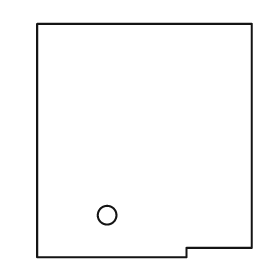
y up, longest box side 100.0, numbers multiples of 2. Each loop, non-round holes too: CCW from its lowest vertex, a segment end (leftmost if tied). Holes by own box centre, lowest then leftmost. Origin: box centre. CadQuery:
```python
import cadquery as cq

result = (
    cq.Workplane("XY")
    .moveTo(-46.0, -50.0)
    .lineTo(18.0, -50.0)
    .lineTo(18.0, -46.0)
    .lineTo(46.0, -46.0)
    .lineTo(46.0, 50.0)
    .lineTo(-46.0, 50.0)
    .close()
    .moveTo(-16.0, -32.0)
    .circle(4.0)
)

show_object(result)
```